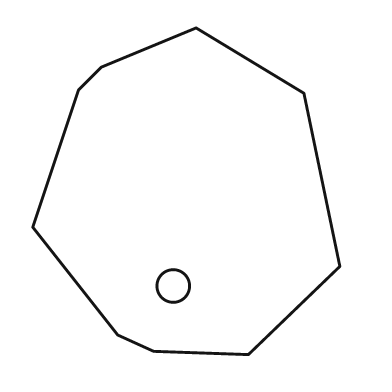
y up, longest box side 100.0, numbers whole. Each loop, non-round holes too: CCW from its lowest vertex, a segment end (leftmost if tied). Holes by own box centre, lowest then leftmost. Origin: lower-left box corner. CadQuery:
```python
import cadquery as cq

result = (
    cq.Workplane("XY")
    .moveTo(66.0, 0.0)
    .lineTo(94.0, 27.0)
    .lineTo(83.0, 80.0)
    .lineTo(50.0, 100.0)
    .lineTo(21.0, 88.0)
    .lineTo(14.0, 81.0)
    .lineTo(0.0, 39.0)
    .lineTo(26.0, 6.0)
    .lineTo(37.0, 1.0)
    .close()
    .moveTo(43.0, 21.0)
    .circle(5.0)
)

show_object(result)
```